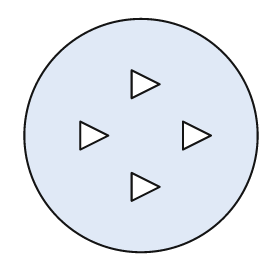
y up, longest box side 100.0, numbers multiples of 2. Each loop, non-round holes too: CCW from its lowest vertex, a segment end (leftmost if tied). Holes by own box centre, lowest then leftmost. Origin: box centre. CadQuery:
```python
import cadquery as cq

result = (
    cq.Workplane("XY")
    .moveTo(0.0, 0.0)
    .circle(50.0)
    .moveTo(-4.0, -28.0)
    .lineTo(8.0, -22.0)
    .lineTo(-4.0, -16.0)
    .close()
    .moveTo(-26.0, -6.0)
    .lineTo(-14.0, 0.0)
    .lineTo(-26.0, 6.0)
    .close()
    .moveTo(18.0, -6.0)
    .lineTo(30.0, 0.0)
    .lineTo(18.0, 6.0)
    .close()
    .moveTo(-4.0, 16.0)
    .lineTo(8.0, 22.0)
    .lineTo(-4.0, 28.0)
    .close()
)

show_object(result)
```